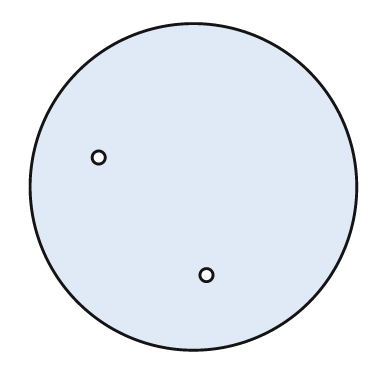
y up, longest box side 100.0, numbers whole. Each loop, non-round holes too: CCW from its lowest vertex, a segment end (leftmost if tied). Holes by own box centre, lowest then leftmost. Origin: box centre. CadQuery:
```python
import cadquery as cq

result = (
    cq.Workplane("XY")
    .moveTo(0.0, 0.0)
    .circle(50.0)
    .moveTo(4.0, -27.0)
    .circle(2.0)
    .moveTo(-29.0, 9.0)
    .circle(2.0)
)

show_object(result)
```